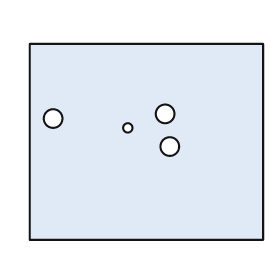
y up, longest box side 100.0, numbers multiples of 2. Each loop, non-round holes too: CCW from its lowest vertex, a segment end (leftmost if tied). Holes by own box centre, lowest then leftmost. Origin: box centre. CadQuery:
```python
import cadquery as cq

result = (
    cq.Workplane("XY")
    .moveTo(-50.0, -42.0)
    .lineTo(50.0, -42.0)
    .lineTo(50.0, 42.0)
    .lineTo(-50.0, 42.0)
    .close()
    .moveTo(10.0, -2.0)
    .circle(4.0)
    .moveTo(-8.0, 6.0)
    .circle(2.0)
    .moveTo(-40.0, 10.0)
    .circle(4.0)
    .moveTo(8.0, 12.0)
    .circle(4.0)
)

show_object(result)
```